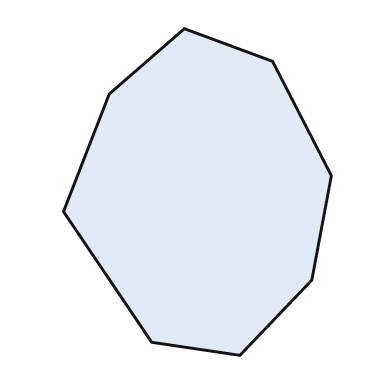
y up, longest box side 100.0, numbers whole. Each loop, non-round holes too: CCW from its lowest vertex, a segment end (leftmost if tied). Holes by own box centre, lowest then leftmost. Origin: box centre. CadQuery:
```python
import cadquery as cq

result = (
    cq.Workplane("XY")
    .moveTo(13.0, -50.0)
    .lineTo(35.0, -27.0)
    .lineTo(41.0, 5.0)
    .lineTo(23.0, 40.0)
    .lineTo(-4.0, 50.0)
    .lineTo(-27.0, 30.0)
    .lineTo(-41.0, -6.0)
    .lineTo(-14.0, -46.0)
    .close()
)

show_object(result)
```